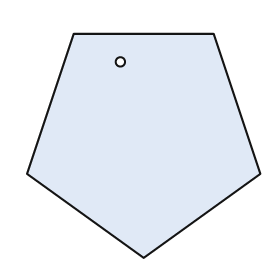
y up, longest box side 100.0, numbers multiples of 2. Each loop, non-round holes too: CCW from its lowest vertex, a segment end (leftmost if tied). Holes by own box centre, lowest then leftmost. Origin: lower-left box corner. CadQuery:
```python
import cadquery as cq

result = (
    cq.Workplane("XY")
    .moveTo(50.0, 0.0)
    .lineTo(100.0, 36.0)
    .lineTo(80.0, 96.0)
    .lineTo(20.0, 96.0)
    .lineTo(0.0, 36.0)
    .close()
    .moveTo(40.0, 84.0)
    .circle(2.0)
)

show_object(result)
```